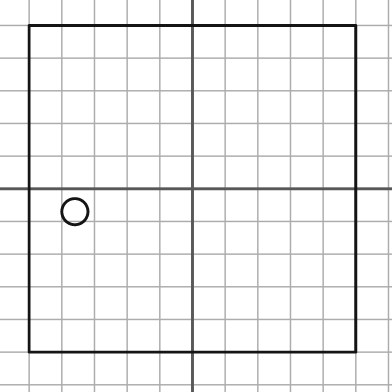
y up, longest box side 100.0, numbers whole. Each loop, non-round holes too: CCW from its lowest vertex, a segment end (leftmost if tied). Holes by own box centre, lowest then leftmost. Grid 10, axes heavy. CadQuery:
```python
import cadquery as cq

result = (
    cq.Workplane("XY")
    .moveTo(-50.0, -50.0)
    .lineTo(50.0, -50.0)
    .lineTo(50.0, 50.0)
    .lineTo(-50.0, 50.0)
    .close()
    .moveTo(-36.0, -7.0)
    .circle(4.0)
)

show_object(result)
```